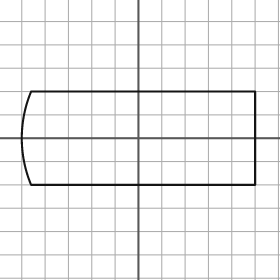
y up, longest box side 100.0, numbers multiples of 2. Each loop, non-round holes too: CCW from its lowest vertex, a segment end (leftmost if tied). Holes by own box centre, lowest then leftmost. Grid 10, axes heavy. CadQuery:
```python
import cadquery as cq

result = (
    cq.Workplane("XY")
    .moveTo(-46.0, -20.0)
    .lineTo(50.0, -20.0)
    .lineTo(50.0, 20.0)
    .lineTo(-46.0, 20.0)
    .threePointArc((-50.0, 0.0), (-46.0, -20.0))
    .close()
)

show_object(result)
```